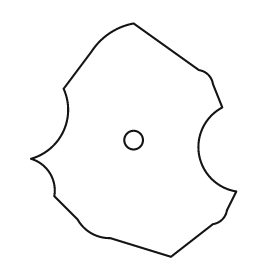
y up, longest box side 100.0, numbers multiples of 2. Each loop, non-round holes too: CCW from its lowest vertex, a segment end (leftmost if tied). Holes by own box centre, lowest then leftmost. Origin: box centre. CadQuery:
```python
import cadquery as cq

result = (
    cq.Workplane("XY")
    .moveTo(16.0, -50.0)
    .lineTo(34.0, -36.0)
    .threePointArc((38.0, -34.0), (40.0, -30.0))
    .lineTo(44.0, -22.0)
    .threePointArc((28.0, -6.0), (38.0, 14.0))
    .lineTo(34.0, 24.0)
    .threePointArc((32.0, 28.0), (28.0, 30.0))
    .lineTo(0.0, 50.0)
    .threePointArc((-10.0, 46.0), (-18.0, 38.0))
    .lineTo(-30.0, 22.0)
    .threePointArc((-30.0, 4.0), (-44.0, -8.0))
    .threePointArc((-36.0, -14.0), (-34.0, -24.0))
    .lineTo(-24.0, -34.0)
    .threePointArc((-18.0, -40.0), (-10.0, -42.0))
    .close()
    .moveTo(0.0, 0.0)
    .circle(4.0)
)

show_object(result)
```